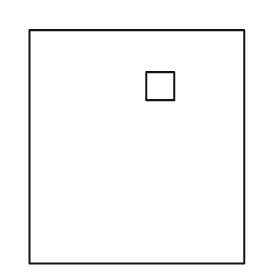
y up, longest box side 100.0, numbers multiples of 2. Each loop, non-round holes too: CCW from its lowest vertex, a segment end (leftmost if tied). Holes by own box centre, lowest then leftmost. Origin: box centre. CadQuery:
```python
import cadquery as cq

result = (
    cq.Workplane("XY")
    .moveTo(-46.0, -50.0)
    .lineTo(46.0, -50.0)
    .lineTo(46.0, 50.0)
    .lineTo(-46.0, 50.0)
    .close()
    .moveTo(4.0, 20.0)
    .lineTo(16.0, 20.0)
    .lineTo(16.0, 32.0)
    .lineTo(4.0, 32.0)
    .close()
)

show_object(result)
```